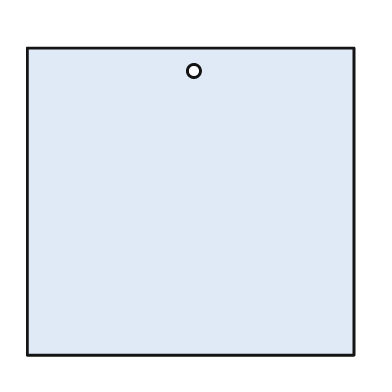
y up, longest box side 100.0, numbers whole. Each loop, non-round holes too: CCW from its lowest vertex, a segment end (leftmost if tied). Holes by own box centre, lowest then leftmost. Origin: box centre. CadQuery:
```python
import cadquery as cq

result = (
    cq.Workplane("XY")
    .moveTo(-50.0, -47.0)
    .lineTo(50.0, -47.0)
    .lineTo(50.0, 47.0)
    .lineTo(-50.0, 47.0)
    .close()
    .moveTo(1.0, 40.0)
    .circle(2.0)
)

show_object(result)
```